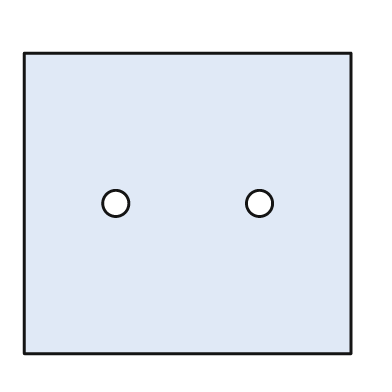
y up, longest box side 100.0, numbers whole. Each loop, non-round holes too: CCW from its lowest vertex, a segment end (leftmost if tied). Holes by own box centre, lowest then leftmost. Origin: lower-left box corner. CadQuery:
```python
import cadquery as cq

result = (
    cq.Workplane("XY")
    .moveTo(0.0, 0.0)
    .lineTo(100.0, 0.0)
    .lineTo(100.0, 92.0)
    .lineTo(0.0, 92.0)
    .close()
    .moveTo(28.0, 46.0)
    .circle(4.0)
    .moveTo(72.0, 46.0)
    .circle(4.0)
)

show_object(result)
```